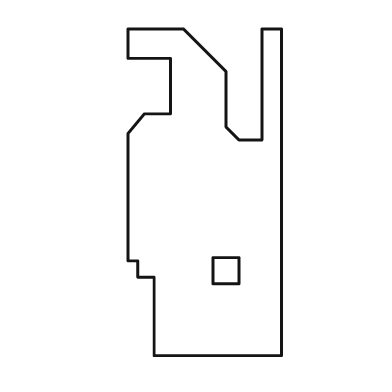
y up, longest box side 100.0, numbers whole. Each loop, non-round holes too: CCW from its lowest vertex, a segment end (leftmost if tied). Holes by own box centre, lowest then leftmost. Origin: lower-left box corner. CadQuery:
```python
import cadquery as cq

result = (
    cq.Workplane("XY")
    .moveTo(8.0, 0.0)
    .lineTo(47.0, 0.0)
    .lineTo(47.0, 100.0)
    .lineTo(41.0, 100.0)
    .lineTo(41.0, 66.0)
    .lineTo(34.0, 66.0)
    .lineTo(30.0, 70.0)
    .lineTo(30.0, 87.0)
    .lineTo(17.0, 100.0)
    .lineTo(0.0, 100.0)
    .lineTo(0.0, 91.0)
    .lineTo(13.0, 91.0)
    .lineTo(13.0, 74.0)
    .lineTo(5.0, 74.0)
    .lineTo(0.0, 68.0)
    .lineTo(0.0, 29.0)
    .lineTo(3.0, 29.0)
    .lineTo(3.0, 24.0)
    .lineTo(8.0, 24.0)
    .close()
    .moveTo(26.0, 22.0)
    .lineTo(34.0, 22.0)
    .lineTo(34.0, 30.0)
    .lineTo(26.0, 30.0)
    .close()
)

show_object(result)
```